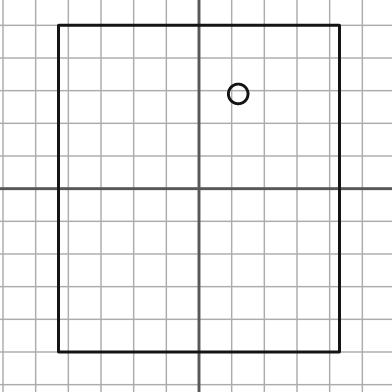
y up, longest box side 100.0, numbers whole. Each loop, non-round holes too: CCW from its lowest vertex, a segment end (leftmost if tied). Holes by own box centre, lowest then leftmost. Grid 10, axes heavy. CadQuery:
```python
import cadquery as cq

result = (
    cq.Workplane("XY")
    .moveTo(-43.0, -50.0)
    .lineTo(43.0, -50.0)
    .lineTo(43.0, 50.0)
    .lineTo(-43.0, 50.0)
    .close()
    .moveTo(12.0, 29.0)
    .circle(3.0)
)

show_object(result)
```